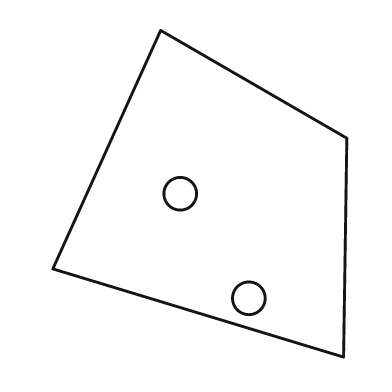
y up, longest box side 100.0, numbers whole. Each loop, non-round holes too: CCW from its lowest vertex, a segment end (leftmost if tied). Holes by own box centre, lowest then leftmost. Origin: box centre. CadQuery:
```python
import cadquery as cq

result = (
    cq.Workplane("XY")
    .moveTo(44.0, -50.0)
    .lineTo(45.0, 17.0)
    .lineTo(-12.0, 50.0)
    .lineTo(-45.0, -23.0)
    .close()
    .moveTo(15.0, -32.0)
    .circle(5.0)
    .moveTo(-6.0, 0.0)
    .circle(5.0)
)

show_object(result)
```